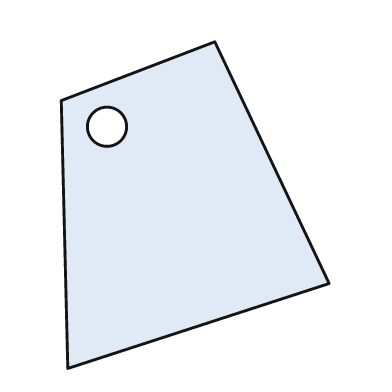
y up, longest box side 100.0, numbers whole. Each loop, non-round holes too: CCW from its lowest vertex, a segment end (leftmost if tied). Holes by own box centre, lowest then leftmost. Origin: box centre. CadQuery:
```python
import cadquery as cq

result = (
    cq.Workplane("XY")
    .moveTo(-39.0, -50.0)
    .lineTo(41.0, -24.0)
    .lineTo(6.0, 50.0)
    .lineTo(-41.0, 32.0)
    .close()
    .moveTo(-27.0, 24.0)
    .circle(6.0)
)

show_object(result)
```